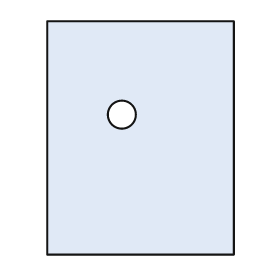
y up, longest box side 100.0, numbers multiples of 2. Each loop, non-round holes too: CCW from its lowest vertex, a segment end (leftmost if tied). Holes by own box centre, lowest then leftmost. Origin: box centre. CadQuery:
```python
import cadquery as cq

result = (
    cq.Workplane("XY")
    .moveTo(-40.0, -50.0)
    .lineTo(40.0, -50.0)
    .lineTo(40.0, 50.0)
    .lineTo(-40.0, 50.0)
    .close()
    .moveTo(-8.0, 10.0)
    .circle(6.0)
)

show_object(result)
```